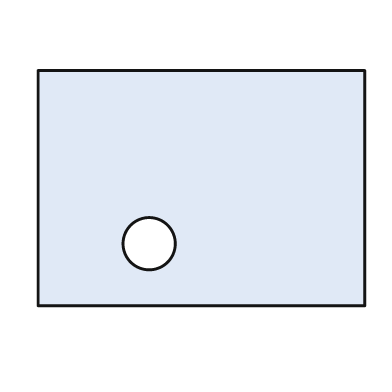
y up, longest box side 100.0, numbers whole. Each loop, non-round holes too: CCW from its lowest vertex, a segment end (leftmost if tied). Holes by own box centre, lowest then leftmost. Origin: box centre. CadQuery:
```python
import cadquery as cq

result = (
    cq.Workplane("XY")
    .moveTo(-50.0, -36.0)
    .lineTo(50.0, -36.0)
    .lineTo(50.0, 36.0)
    .lineTo(-50.0, 36.0)
    .close()
    .moveTo(-16.0, -17.0)
    .circle(8.0)
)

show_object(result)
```